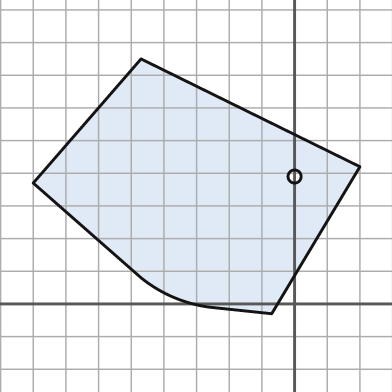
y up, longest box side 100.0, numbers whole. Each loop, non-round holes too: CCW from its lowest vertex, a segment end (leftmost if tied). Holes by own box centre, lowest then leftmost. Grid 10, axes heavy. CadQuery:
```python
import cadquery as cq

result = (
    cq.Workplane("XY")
    .moveTo(-7.0, -3.0)
    .lineTo(20.0, 42.0)
    .lineTo(-47.0, 75.0)
    .lineTo(-80.0, 37.0)
    .lineTo(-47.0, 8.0)
    .threePointArc((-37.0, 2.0), (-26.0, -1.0))
    .close()
    .moveTo(0.0, 39.0)
    .circle(2.0)
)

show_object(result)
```